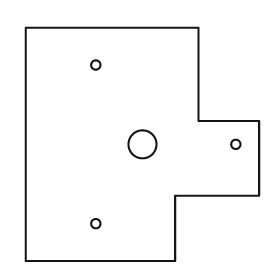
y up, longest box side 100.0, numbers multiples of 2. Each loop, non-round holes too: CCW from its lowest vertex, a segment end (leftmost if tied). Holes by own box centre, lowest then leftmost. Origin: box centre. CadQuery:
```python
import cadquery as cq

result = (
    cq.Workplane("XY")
    .moveTo(-50.0, -50.0)
    .lineTo(14.0, -50.0)
    .lineTo(14.0, -22.0)
    .lineTo(50.0, -22.0)
    .lineTo(50.0, 10.0)
    .lineTo(24.0, 10.0)
    .lineTo(24.0, 50.0)
    .lineTo(-50.0, 50.0)
    .close()
    .moveTo(-20.0, -34.0)
    .circle(2.0)
    .moveTo(0.0, 0.0)
    .circle(6.0)
    .moveTo(40.0, 0.0)
    .circle(2.0)
    .moveTo(-20.0, 34.0)
    .circle(2.0)
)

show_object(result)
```